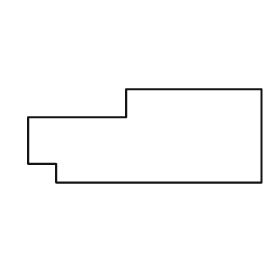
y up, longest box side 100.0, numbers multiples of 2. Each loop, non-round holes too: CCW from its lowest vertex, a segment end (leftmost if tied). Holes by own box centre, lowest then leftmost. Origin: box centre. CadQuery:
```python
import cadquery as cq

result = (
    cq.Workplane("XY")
    .moveTo(-38.0, -20.0)
    .lineTo(50.0, -20.0)
    .lineTo(50.0, 20.0)
    .lineTo(-8.0, 20.0)
    .lineTo(-8.0, 8.0)
    .lineTo(-50.0, 8.0)
    .lineTo(-50.0, -12.0)
    .lineTo(-38.0, -12.0)
    .close()
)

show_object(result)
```